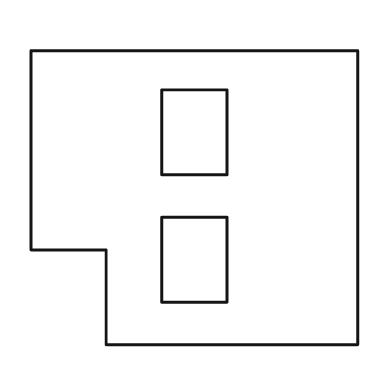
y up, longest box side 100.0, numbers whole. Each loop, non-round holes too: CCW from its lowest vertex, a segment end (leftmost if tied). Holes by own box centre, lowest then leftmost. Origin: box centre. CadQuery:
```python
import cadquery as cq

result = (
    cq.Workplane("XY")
    .moveTo(-27.0, -45.0)
    .lineTo(50.0, -45.0)
    .lineTo(50.0, 45.0)
    .lineTo(-50.0, 45.0)
    .lineTo(-50.0, -16.0)
    .lineTo(-27.0, -16.0)
    .close()
    .moveTo(-10.0, -32.0)
    .lineTo(10.0, -32.0)
    .lineTo(10.0, -6.0)
    .lineTo(-10.0, -6.0)
    .close()
    .moveTo(-10.0, 7.0)
    .lineTo(10.0, 7.0)
    .lineTo(10.0, 33.0)
    .lineTo(-10.0, 33.0)
    .close()
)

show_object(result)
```